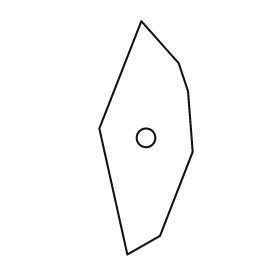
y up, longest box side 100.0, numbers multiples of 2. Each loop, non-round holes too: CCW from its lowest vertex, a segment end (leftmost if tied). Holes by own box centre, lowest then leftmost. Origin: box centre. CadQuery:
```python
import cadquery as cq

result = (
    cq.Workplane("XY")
    .moveTo(-8.0, -50.0)
    .lineTo(6.0, -42.0)
    .lineTo(20.0, -6.0)
    .lineTo(18.0, 20.0)
    .lineTo(14.0, 32.0)
    .lineTo(-2.0, 50.0)
    .lineTo(-20.0, 4.0)
    .close()
    .moveTo(0.0, 0.0)
    .circle(4.0)
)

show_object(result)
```